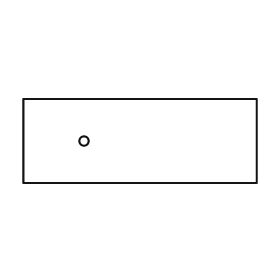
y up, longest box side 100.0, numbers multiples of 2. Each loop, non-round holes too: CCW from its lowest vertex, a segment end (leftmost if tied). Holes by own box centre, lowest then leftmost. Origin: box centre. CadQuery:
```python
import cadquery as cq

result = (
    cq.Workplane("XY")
    .moveTo(-50.0, -18.0)
    .lineTo(50.0, -18.0)
    .lineTo(50.0, 18.0)
    .lineTo(-50.0, 18.0)
    .close()
    .moveTo(-24.0, 0.0)
    .circle(2.0)
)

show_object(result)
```